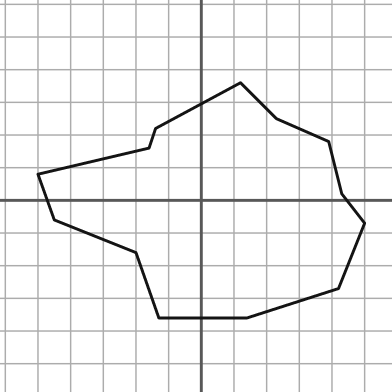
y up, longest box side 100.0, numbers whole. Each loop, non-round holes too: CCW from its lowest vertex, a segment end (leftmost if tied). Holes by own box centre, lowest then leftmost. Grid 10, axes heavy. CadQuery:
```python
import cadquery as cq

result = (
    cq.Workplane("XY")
    .moveTo(-13.0, -36.0)
    .lineTo(14.0, -36.0)
    .lineTo(42.0, -27.0)
    .lineTo(50.0, -7.0)
    .lineTo(43.0, 2.0)
    .lineTo(39.0, 18.0)
    .lineTo(23.0, 25.0)
    .lineTo(12.0, 36.0)
    .lineTo(-14.0, 22.0)
    .lineTo(-16.0, 16.0)
    .lineTo(-50.0, 8.0)
    .lineTo(-45.0, -6.0)
    .lineTo(-20.0, -16.0)
    .close()
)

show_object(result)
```